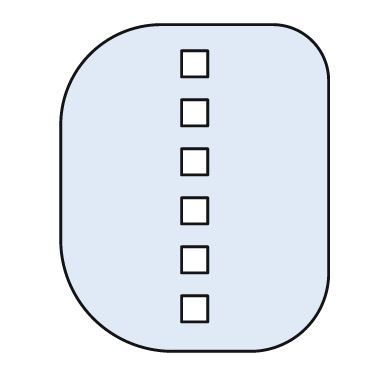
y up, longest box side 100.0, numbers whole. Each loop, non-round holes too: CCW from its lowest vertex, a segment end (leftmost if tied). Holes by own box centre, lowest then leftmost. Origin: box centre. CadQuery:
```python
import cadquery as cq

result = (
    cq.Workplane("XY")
    .moveTo(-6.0, -50.0)
    .lineTo(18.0, -50.0)
    .threePointArc((34.0, -43.0), (41.0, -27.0))
    .lineTo(41.0, 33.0)
    .threePointArc((36.0, 45.0), (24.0, 50.0))
    .lineTo(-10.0, 50.0)
    .threePointArc((-32.0, 41.0), (-41.0, 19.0))
    .lineTo(-41.0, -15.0)
    .threePointArc((-31.0, -40.0), (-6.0, -50.0))
    .close()
    .moveTo(-4.0, -41.0)
    .lineTo(4.0, -41.0)
    .lineTo(4.0, -33.0)
    .lineTo(-4.0, -33.0)
    .close()
    .moveTo(-4.0, -26.0)
    .lineTo(4.0, -26.0)
    .lineTo(4.0, -18.0)
    .lineTo(-4.0, -18.0)
    .close()
    .moveTo(-4.0, -11.0)
    .lineTo(4.0, -11.0)
    .lineTo(4.0, -3.0)
    .lineTo(-4.0, -3.0)
    .close()
    .moveTo(-4.0, 4.0)
    .lineTo(4.0, 4.0)
    .lineTo(4.0, 12.0)
    .lineTo(-4.0, 12.0)
    .close()
    .moveTo(-4.0, 19.0)
    .lineTo(4.0, 19.0)
    .lineTo(4.0, 27.0)
    .lineTo(-4.0, 27.0)
    .close()
    .moveTo(-4.0, 34.0)
    .lineTo(4.0, 34.0)
    .lineTo(4.0, 42.0)
    .lineTo(-4.0, 42.0)
    .close()
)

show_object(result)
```